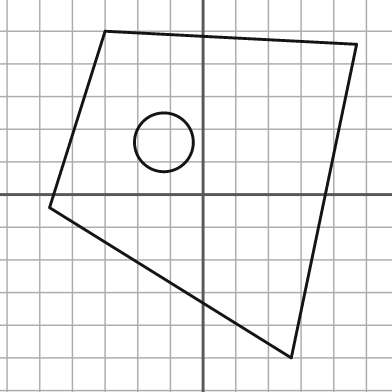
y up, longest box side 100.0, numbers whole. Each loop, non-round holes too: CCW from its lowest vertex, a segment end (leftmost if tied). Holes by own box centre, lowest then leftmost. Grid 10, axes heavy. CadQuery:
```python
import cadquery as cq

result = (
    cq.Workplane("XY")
    .moveTo(27.0, -50.0)
    .lineTo(47.0, 46.0)
    .lineTo(-30.0, 50.0)
    .lineTo(-47.0, -4.0)
    .close()
    .moveTo(-12.0, 16.0)
    .circle(9.0)
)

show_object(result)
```